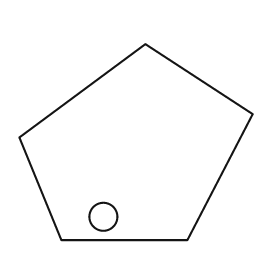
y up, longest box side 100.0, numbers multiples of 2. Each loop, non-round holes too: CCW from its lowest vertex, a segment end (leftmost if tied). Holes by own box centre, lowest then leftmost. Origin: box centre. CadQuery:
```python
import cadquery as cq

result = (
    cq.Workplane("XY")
    .moveTo(-32.0, -42.0)
    .lineTo(22.0, -42.0)
    .lineTo(50.0, 12.0)
    .lineTo(4.0, 42.0)
    .lineTo(-50.0, 2.0)
    .close()
    .moveTo(-14.0, -32.0)
    .circle(6.0)
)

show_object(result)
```